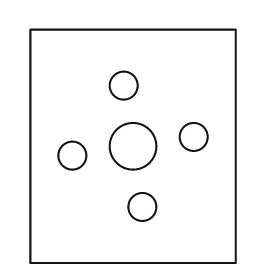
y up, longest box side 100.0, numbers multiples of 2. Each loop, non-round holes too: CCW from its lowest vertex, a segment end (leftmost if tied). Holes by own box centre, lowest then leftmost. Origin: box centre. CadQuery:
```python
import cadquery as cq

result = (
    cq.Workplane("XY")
    .moveTo(-44.0, -50.0)
    .lineTo(44.0, -50.0)
    .lineTo(44.0, 50.0)
    .lineTo(-44.0, 50.0)
    .close()
    .moveTo(4.0, -26.0)
    .circle(6.0)
    .moveTo(-26.0, -4.0)
    .circle(6.0)
    .moveTo(0.0, 0.0)
    .circle(10.0)
    .moveTo(26.0, 4.0)
    .circle(6.0)
    .moveTo(-4.0, 26.0)
    .circle(6.0)
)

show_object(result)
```